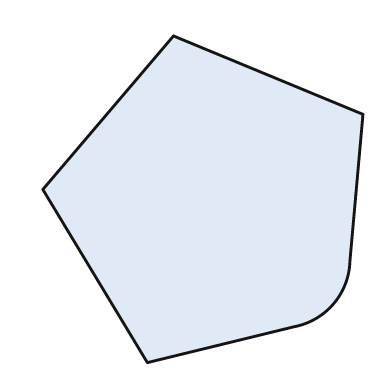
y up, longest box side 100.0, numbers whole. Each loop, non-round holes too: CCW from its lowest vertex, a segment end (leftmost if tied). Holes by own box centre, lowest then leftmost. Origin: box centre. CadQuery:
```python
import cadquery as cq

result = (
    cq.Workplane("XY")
    .moveTo(-17.0, -50.0)
    .lineTo(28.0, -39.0)
    .threePointArc((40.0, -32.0), (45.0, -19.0))
    .lineTo(49.0, 26.0)
    .lineTo(-9.0, 50.0)
    .lineTo(-49.0, 3.0)
    .close()
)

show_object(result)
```